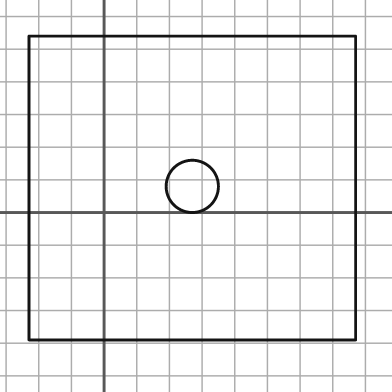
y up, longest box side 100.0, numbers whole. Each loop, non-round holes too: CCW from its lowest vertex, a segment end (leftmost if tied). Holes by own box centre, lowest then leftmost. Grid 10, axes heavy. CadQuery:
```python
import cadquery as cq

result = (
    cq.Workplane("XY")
    .moveTo(-23.0, -39.0)
    .lineTo(77.0, -39.0)
    .lineTo(77.0, 54.0)
    .lineTo(-23.0, 54.0)
    .close()
    .moveTo(27.0, 8.0)
    .circle(8.0)
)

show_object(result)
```